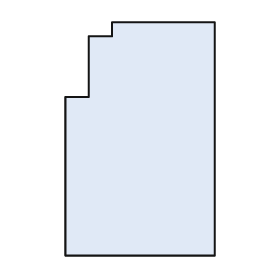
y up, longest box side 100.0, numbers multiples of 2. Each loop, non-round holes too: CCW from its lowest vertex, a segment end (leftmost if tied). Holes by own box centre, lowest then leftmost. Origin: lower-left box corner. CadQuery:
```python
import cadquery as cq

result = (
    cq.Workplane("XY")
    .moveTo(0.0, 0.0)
    .lineTo(64.0, 0.0)
    .lineTo(64.0, 100.0)
    .lineTo(20.0, 100.0)
    .lineTo(20.0, 94.0)
    .lineTo(10.0, 94.0)
    .lineTo(10.0, 68.0)
    .lineTo(0.0, 68.0)
    .close()
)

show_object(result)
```